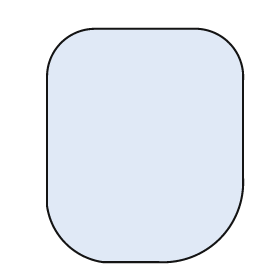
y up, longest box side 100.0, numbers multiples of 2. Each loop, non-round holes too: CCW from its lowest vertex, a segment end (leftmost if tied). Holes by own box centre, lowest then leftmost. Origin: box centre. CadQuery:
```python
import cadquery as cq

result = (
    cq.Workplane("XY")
    .moveTo(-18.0, -50.0)
    .lineTo(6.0, -50.0)
    .threePointArc((32.0, -40.0), (42.0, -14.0))
    .lineTo(42.0, 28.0)
    .threePointArc((36.0, 44.0), (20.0, 50.0))
    .lineTo(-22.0, 50.0)
    .threePointArc((-36.0, 44.0), (-42.0, 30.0))
    .lineTo(-42.0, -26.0)
    .threePointArc((-34.0, -42.0), (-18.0, -50.0))
    .close()
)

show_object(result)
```